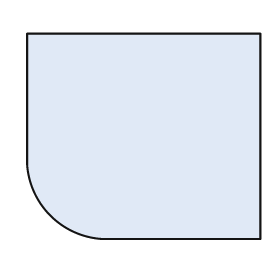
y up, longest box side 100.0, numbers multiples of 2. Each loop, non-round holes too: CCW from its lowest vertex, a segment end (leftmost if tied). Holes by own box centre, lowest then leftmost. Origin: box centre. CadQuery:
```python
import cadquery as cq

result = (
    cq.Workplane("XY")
    .moveTo(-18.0, -44.0)
    .lineTo(50.0, -44.0)
    .lineTo(50.0, 44.0)
    .lineTo(-50.0, 44.0)
    .lineTo(-50.0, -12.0)
    .threePointArc((-40.0, -34.0), (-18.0, -44.0))
    .close()
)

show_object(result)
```